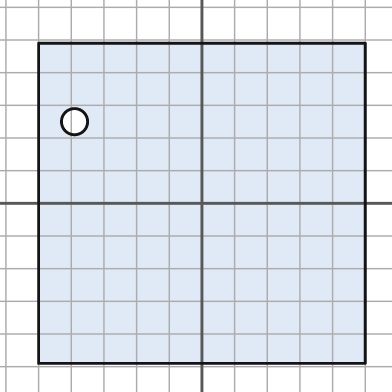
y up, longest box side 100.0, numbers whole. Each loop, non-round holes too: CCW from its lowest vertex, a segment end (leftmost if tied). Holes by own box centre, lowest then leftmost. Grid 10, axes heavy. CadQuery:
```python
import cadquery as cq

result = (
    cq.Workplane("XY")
    .moveTo(-50.0, -49.0)
    .lineTo(50.0, -49.0)
    .lineTo(50.0, 49.0)
    .lineTo(-50.0, 49.0)
    .close()
    .moveTo(-39.0, 25.0)
    .circle(4.0)
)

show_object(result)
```